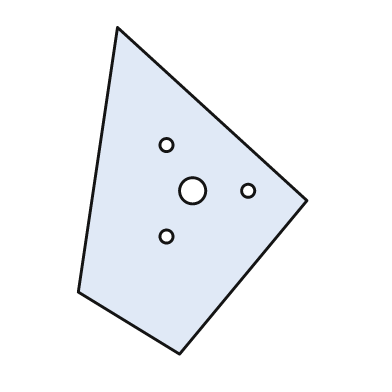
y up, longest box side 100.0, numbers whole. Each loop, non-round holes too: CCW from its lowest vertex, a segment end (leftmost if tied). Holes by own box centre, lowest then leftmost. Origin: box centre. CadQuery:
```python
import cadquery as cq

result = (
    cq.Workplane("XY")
    .moveTo(-4.0, -50.0)
    .lineTo(35.0, -3.0)
    .lineTo(-23.0, 50.0)
    .lineTo(-35.0, -31.0)
    .close()
    .moveTo(-8.0, -14.0)
    .circle(2.0)
    .moveTo(0.0, 0.0)
    .circle(4.0)
    .moveTo(17.0, 0.0)
    .circle(2.0)
    .moveTo(-8.0, 14.0)
    .circle(2.0)
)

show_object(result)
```